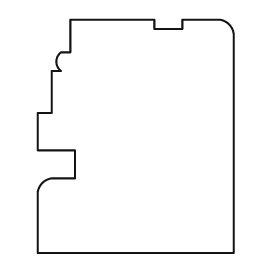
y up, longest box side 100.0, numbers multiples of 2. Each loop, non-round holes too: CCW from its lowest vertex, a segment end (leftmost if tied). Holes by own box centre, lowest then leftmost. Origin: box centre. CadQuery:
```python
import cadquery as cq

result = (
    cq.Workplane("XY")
    .moveTo(-42.0, -50.0)
    .lineTo(42.0, -50.0)
    .lineTo(42.0, 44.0)
    .threePointArc((40.0, 48.0), (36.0, 50.0))
    .lineTo(20.0, 50.0)
    .lineTo(20.0, 46.0)
    .lineTo(8.0, 46.0)
    .lineTo(8.0, 50.0)
    .lineTo(-28.0, 50.0)
    .lineTo(-28.0, 36.0)
    .lineTo(-32.0, 36.0)
    .threePointArc((-34.0, 32.0), (-32.0, 28.0))
    .lineTo(-36.0, 28.0)
    .lineTo(-36.0, 10.0)
    .lineTo(-42.0, 10.0)
    .lineTo(-42.0, -6.0)
    .lineTo(-26.0, -6.0)
    .lineTo(-26.0, -18.0)
    .lineTo(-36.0, -18.0)
    .threePointArc((-40.0, -20.0), (-42.0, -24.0))
    .close()
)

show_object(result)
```